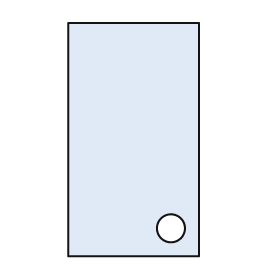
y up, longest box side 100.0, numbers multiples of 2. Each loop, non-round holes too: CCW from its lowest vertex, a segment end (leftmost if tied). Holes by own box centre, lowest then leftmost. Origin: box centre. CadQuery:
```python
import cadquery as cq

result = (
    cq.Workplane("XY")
    .moveTo(-28.0, -50.0)
    .lineTo(28.0, -50.0)
    .lineTo(28.0, 50.0)
    .lineTo(-28.0, 50.0)
    .close()
    .moveTo(16.0, -38.0)
    .circle(6.0)
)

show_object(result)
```